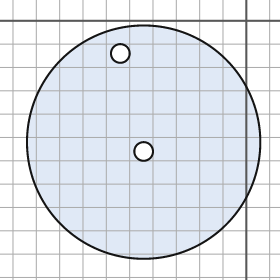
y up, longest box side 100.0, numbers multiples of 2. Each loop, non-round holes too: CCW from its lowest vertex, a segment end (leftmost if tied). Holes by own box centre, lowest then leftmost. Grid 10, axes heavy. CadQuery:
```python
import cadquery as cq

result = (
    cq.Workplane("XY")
    .moveTo(-44.0, -52.0)
    .circle(50.0)
    .moveTo(-44.0, -56.0)
    .circle(4.0)
    .moveTo(-54.0, -14.0)
    .circle(4.0)
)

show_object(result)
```